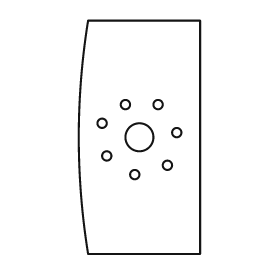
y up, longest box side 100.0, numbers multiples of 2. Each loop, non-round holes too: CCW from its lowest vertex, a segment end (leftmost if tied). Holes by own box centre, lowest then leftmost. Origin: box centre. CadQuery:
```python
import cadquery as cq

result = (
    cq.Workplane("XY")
    .moveTo(-22.0, -50.0)
    .lineTo(26.0, -50.0)
    .lineTo(26.0, 50.0)
    .lineTo(-22.0, 50.0)
    .threePointArc((-26.0, 0.0), (-22.0, -50.0))
    .close()
    .moveTo(-2.0, -16.0)
    .circle(2.0)
    .moveTo(12.0, -12.0)
    .circle(2.0)
    .moveTo(-14.0, -8.0)
    .circle(2.0)
    .moveTo(0.0, 0.0)
    .circle(6.0)
    .moveTo(16.0, 2.0)
    .circle(2.0)
    .moveTo(-16.0, 6.0)
    .circle(2.0)
    .moveTo(-6.0, 14.0)
    .circle(2.0)
    .moveTo(8.0, 14.0)
    .circle(2.0)
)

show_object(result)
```